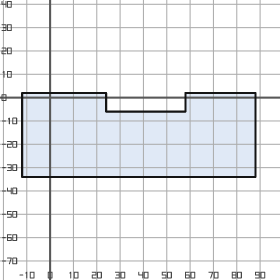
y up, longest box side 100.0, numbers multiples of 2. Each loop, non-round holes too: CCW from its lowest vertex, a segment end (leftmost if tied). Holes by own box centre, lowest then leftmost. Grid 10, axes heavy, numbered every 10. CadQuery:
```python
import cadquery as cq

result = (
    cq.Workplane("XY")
    .moveTo(-12.0, -34.0)
    .lineTo(88.0, -34.0)
    .lineTo(88.0, 2.0)
    .lineTo(58.0, 2.0)
    .lineTo(58.0, -6.0)
    .lineTo(24.0, -6.0)
    .lineTo(24.0, 2.0)
    .lineTo(-12.0, 2.0)
    .close()
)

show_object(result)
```